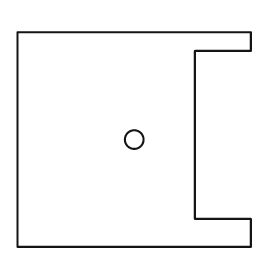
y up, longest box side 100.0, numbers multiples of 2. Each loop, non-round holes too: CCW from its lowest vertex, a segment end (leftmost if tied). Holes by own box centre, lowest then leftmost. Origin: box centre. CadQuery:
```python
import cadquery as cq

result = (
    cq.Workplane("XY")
    .moveTo(-50.0, -46.0)
    .lineTo(50.0, -46.0)
    .lineTo(50.0, -34.0)
    .lineTo(26.0, -34.0)
    .lineTo(26.0, 38.0)
    .lineTo(50.0, 38.0)
    .lineTo(50.0, 46.0)
    .lineTo(-50.0, 46.0)
    .close()
    .moveTo(0.0, 0.0)
    .circle(4.0)
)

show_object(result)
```